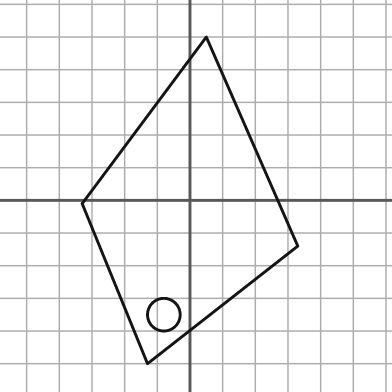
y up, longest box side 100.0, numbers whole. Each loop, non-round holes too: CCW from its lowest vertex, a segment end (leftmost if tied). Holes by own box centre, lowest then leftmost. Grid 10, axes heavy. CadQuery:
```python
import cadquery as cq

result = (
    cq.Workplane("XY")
    .moveTo(-13.0, -50.0)
    .lineTo(33.0, -14.0)
    .lineTo(5.0, 50.0)
    .lineTo(-33.0, -1.0)
    .close()
    .moveTo(-8.0, -35.0)
    .circle(5.0)
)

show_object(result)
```